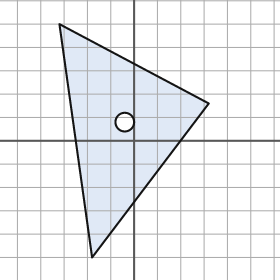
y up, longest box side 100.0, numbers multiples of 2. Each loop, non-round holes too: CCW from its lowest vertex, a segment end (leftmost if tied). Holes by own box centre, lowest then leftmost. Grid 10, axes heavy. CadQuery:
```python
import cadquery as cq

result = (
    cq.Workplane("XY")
    .moveTo(-18.0, -50.0)
    .lineTo(32.0, 16.0)
    .lineTo(-32.0, 50.0)
    .close()
    .moveTo(-4.0, 8.0)
    .circle(4.0)
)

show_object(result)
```